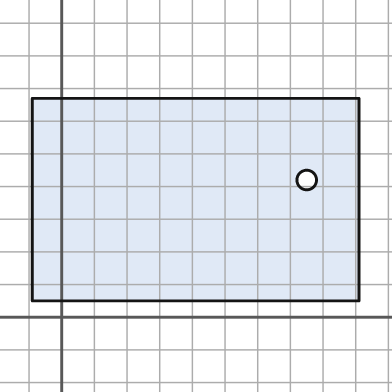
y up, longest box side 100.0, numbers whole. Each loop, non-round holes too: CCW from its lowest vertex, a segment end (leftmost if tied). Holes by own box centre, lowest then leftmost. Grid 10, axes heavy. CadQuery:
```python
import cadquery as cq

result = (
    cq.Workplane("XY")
    .moveTo(-9.0, 5.0)
    .lineTo(91.0, 5.0)
    .lineTo(91.0, 67.0)
    .lineTo(-9.0, 67.0)
    .close()
    .moveTo(75.0, 42.0)
    .circle(3.0)
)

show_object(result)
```